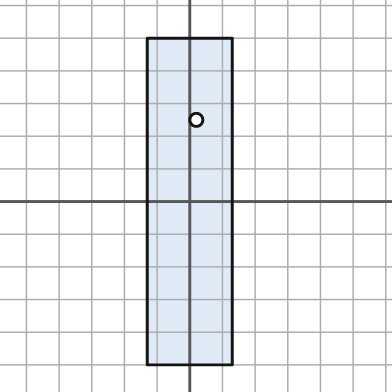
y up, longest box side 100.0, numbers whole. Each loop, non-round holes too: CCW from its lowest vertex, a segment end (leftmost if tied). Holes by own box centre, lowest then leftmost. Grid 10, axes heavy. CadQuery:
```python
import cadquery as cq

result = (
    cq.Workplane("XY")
    .moveTo(-13.0, -50.0)
    .lineTo(13.0, -50.0)
    .lineTo(13.0, 50.0)
    .lineTo(-13.0, 50.0)
    .close()
    .moveTo(2.0, 25.0)
    .circle(2.0)
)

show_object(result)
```